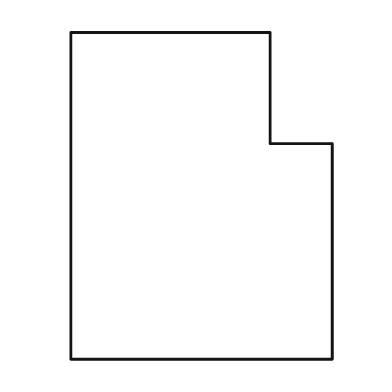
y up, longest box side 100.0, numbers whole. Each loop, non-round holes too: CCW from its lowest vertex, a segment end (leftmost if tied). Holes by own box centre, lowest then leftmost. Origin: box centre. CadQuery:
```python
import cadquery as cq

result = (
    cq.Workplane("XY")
    .moveTo(-40.0, -50.0)
    .lineTo(40.0, -50.0)
    .lineTo(40.0, 16.0)
    .lineTo(21.0, 16.0)
    .lineTo(21.0, 50.0)
    .lineTo(-40.0, 50.0)
    .close()
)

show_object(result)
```